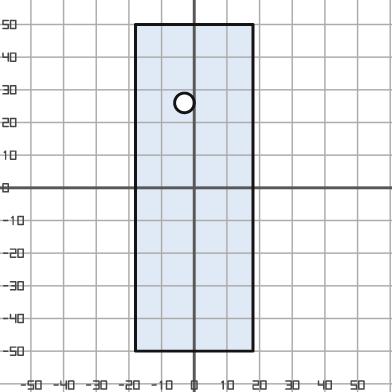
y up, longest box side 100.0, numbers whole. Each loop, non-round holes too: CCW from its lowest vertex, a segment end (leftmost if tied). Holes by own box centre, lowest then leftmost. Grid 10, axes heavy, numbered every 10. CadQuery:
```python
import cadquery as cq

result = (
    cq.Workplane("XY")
    .moveTo(-18.0, -50.0)
    .lineTo(18.0, -50.0)
    .lineTo(18.0, 50.0)
    .lineTo(-18.0, 50.0)
    .close()
    .moveTo(-3.0, 26.0)
    .circle(3.0)
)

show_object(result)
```